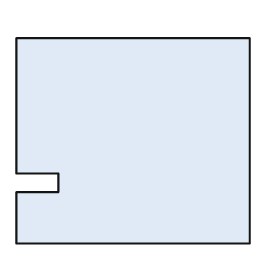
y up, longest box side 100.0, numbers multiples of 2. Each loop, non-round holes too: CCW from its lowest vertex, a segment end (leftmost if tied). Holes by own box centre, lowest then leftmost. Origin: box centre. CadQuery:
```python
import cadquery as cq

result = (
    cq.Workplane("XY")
    .moveTo(-50.0, -44.0)
    .lineTo(50.0, -44.0)
    .lineTo(50.0, 44.0)
    .lineTo(-50.0, 44.0)
    .lineTo(-50.0, -14.0)
    .lineTo(-32.0, -14.0)
    .lineTo(-32.0, -22.0)
    .lineTo(-50.0, -22.0)
    .close()
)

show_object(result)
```